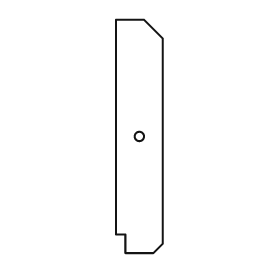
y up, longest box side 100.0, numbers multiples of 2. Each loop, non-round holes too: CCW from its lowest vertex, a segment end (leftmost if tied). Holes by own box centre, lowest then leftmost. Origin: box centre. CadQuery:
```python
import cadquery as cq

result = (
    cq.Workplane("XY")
    .moveTo(-6.0, -50.0)
    .lineTo(6.0, -50.0)
    .lineTo(10.0, -46.0)
    .lineTo(10.0, 42.0)
    .lineTo(2.0, 50.0)
    .lineTo(-10.0, 50.0)
    .lineTo(-10.0, -42.0)
    .lineTo(-6.0, -42.0)
    .close()
    .moveTo(0.0, 0.0)
    .circle(2.0)
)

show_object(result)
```